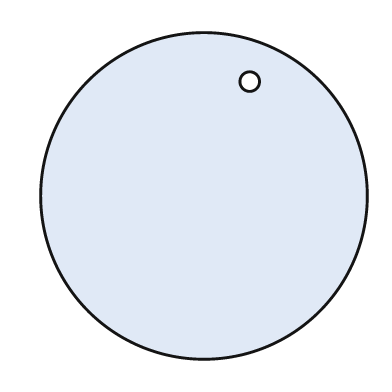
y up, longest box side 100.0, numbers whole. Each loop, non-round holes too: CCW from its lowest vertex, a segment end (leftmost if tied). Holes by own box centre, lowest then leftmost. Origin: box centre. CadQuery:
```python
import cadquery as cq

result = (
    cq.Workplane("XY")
    .moveTo(0.0, 0.0)
    .circle(50.0)
    .moveTo(14.0, 35.0)
    .circle(3.0)
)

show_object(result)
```